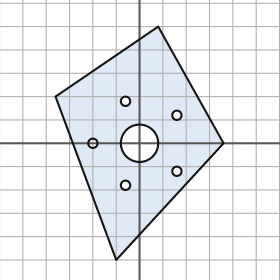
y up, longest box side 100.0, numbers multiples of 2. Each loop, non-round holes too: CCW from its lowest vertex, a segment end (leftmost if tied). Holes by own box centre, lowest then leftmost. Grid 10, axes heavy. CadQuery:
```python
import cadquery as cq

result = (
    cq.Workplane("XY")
    .moveTo(-10.0, -50.0)
    .lineTo(36.0, 0.0)
    .lineTo(8.0, 50.0)
    .lineTo(-36.0, 20.0)
    .close()
    .moveTo(-6.0, -18.0)
    .circle(2.0)
    .moveTo(16.0, -12.0)
    .circle(2.0)
    .moveTo(-20.0, 0.0)
    .circle(2.0)
    .moveTo(0.0, 0.0)
    .circle(8.0)
    .moveTo(16.0, 12.0)
    .circle(2.0)
    .moveTo(-6.0, 18.0)
    .circle(2.0)
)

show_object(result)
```